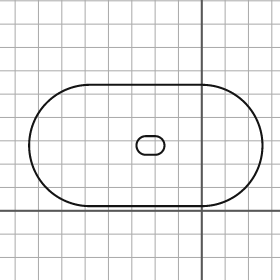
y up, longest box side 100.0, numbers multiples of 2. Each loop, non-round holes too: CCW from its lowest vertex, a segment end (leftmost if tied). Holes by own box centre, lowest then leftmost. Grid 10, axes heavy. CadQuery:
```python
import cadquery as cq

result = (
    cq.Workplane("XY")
    .moveTo(-48.0, 2.0)
    .lineTo(0.0, 2.0)
    .threePointArc((26.0, 28.0), (0.0, 54.0))
    .lineTo(-48.0, 54.0)
    .threePointArc((-74.0, 28.0), (-48.0, 2.0))
    .close()
    .moveTo(-24.0, 24.0)
    .lineTo(-20.0, 24.0)
    .threePointArc((-16.0, 28.0), (-20.0, 32.0))
    .lineTo(-24.0, 32.0)
    .threePointArc((-28.0, 28.0), (-24.0, 24.0))
    .close()
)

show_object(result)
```